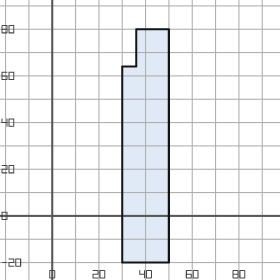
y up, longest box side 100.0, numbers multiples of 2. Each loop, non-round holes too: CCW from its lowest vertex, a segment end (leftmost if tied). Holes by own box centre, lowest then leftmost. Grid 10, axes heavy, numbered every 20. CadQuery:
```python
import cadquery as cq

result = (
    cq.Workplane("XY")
    .moveTo(30.0, -20.0)
    .lineTo(50.0, -20.0)
    .lineTo(50.0, 80.0)
    .lineTo(36.0, 80.0)
    .lineTo(36.0, 64.0)
    .lineTo(30.0, 64.0)
    .close()
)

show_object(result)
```